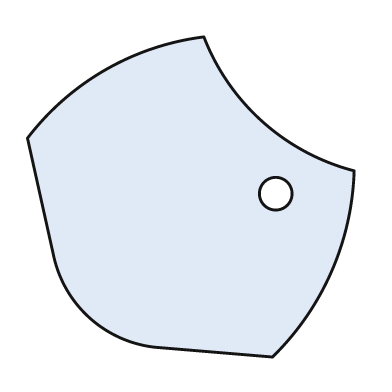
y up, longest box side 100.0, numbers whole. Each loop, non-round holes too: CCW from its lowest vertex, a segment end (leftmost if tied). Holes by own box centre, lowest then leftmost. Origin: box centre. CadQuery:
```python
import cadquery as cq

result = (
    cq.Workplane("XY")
    .moveTo(25.0, -49.0)
    .threePointArc((43.0, -23.0), (50.0, 8.0))
    .threePointArc((22.0, 23.0), (4.0, 49.0))
    .threePointArc((-26.0, 39.0), (-50.0, 18.0))
    .lineTo(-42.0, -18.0)
    .threePointArc((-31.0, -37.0), (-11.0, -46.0))
    .close()
    .moveTo(26.0, 1.0)
    .circle(5.0)
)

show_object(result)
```